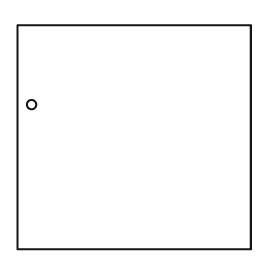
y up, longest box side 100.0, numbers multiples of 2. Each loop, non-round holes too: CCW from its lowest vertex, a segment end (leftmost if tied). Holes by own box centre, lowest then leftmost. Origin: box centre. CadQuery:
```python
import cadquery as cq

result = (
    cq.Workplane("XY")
    .moveTo(-50.0, -48.0)
    .lineTo(50.0, -48.0)
    .lineTo(50.0, 48.0)
    .lineTo(-50.0, 48.0)
    .close()
    .moveTo(-44.0, 14.0)
    .circle(2.0)
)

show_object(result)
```